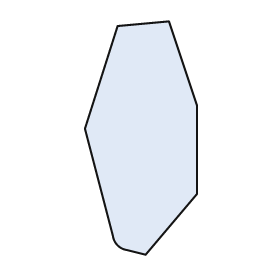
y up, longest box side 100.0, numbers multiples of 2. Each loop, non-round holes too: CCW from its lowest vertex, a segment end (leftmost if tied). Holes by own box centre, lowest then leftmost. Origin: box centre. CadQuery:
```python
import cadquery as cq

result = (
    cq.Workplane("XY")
    .moveTo(2.0, -50.0)
    .lineTo(24.0, -24.0)
    .lineTo(24.0, 14.0)
    .lineTo(12.0, 50.0)
    .lineTo(-10.0, 48.0)
    .lineTo(-24.0, 4.0)
    .lineTo(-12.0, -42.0)
    .threePointArc((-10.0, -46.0), (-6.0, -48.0))
    .close()
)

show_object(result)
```